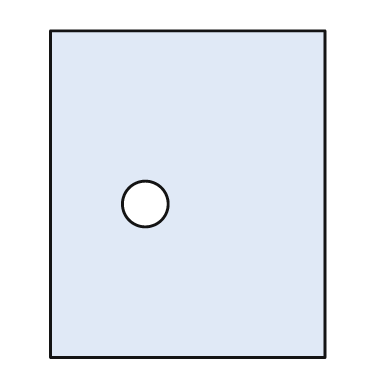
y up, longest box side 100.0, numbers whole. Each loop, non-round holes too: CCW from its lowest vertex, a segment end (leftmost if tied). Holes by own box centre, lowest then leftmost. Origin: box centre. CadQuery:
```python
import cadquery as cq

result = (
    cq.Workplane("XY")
    .moveTo(-42.0, -50.0)
    .lineTo(42.0, -50.0)
    .lineTo(42.0, 50.0)
    .lineTo(-42.0, 50.0)
    .close()
    .moveTo(-13.0, -3.0)
    .circle(7.0)
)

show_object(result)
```